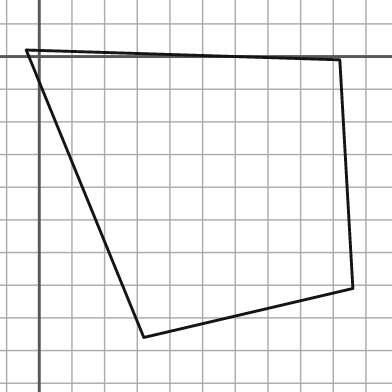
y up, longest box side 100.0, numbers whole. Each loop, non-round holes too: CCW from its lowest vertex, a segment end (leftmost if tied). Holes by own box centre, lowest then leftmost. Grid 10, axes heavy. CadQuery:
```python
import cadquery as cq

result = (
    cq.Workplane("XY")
    .moveTo(32.0, -86.0)
    .lineTo(96.0, -71.0)
    .lineTo(92.0, -1.0)
    .lineTo(-4.0, 2.0)
    .close()
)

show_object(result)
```